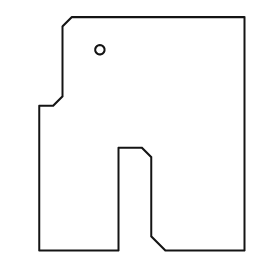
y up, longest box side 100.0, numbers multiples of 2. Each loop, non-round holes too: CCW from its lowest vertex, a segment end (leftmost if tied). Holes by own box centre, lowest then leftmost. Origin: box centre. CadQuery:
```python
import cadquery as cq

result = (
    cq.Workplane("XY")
    .moveTo(-44.0, -50.0)
    .lineTo(-10.0, -50.0)
    .lineTo(-10.0, -6.0)
    .lineTo(0.0, -6.0)
    .lineTo(4.0, -10.0)
    .lineTo(4.0, -44.0)
    .lineTo(10.0, -50.0)
    .lineTo(44.0, -50.0)
    .lineTo(44.0, 50.0)
    .lineTo(-30.0, 50.0)
    .lineTo(-34.0, 46.0)
    .lineTo(-34.0, 16.0)
    .lineTo(-38.0, 12.0)
    .lineTo(-44.0, 12.0)
    .close()
    .moveTo(-18.0, 36.0)
    .circle(2.0)
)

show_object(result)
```